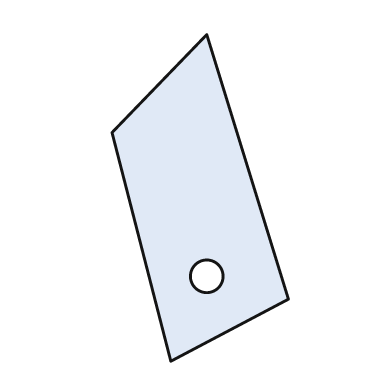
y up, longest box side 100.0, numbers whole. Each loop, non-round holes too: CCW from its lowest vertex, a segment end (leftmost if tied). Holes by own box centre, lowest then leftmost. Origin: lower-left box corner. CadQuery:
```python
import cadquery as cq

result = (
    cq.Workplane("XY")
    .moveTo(18.0, 0.0)
    .lineTo(54.0, 19.0)
    .lineTo(29.0, 100.0)
    .lineTo(0.0, 70.0)
    .close()
    .moveTo(29.0, 26.0)
    .circle(5.0)
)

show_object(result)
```